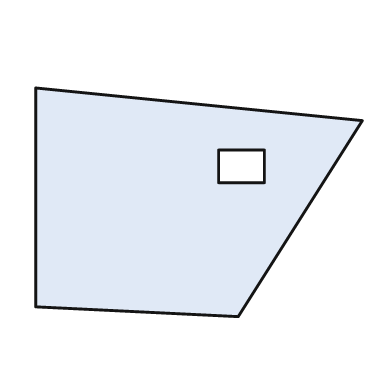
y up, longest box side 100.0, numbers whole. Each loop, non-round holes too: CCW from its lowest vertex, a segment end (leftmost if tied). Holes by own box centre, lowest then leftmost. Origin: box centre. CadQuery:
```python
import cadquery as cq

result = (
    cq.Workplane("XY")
    .moveTo(12.0, -35.0)
    .lineTo(50.0, 25.0)
    .lineTo(-50.0, 35.0)
    .lineTo(-50.0, -32.0)
    .close()
    .moveTo(6.0, 6.0)
    .lineTo(20.0, 6.0)
    .lineTo(20.0, 16.0)
    .lineTo(6.0, 16.0)
    .close()
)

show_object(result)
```